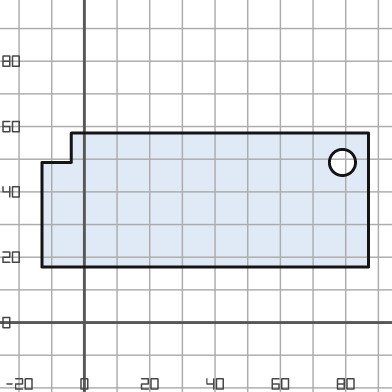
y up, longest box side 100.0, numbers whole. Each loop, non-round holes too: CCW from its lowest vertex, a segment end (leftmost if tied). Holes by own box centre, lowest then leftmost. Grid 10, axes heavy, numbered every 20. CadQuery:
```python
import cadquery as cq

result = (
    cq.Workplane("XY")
    .moveTo(-13.0, 17.0)
    .lineTo(87.0, 17.0)
    .lineTo(87.0, 58.0)
    .lineTo(-4.0, 58.0)
    .lineTo(-4.0, 49.0)
    .lineTo(-13.0, 49.0)
    .close()
    .moveTo(79.0, 49.0)
    .circle(4.0)
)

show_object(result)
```